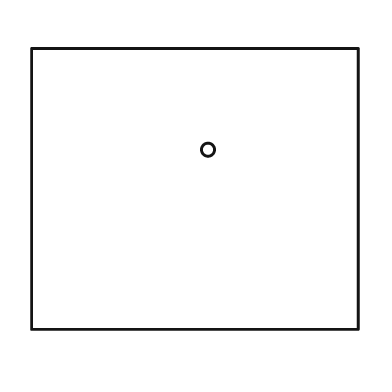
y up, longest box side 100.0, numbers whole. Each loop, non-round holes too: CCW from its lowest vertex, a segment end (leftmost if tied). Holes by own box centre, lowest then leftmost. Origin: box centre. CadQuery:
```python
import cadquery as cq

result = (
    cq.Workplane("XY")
    .moveTo(-50.0, -43.0)
    .lineTo(50.0, -43.0)
    .lineTo(50.0, 43.0)
    .lineTo(-50.0, 43.0)
    .close()
    .moveTo(4.0, 12.0)
    .circle(2.0)
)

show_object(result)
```